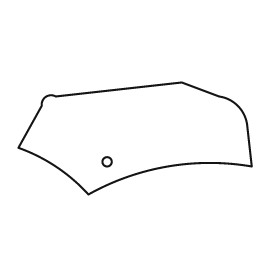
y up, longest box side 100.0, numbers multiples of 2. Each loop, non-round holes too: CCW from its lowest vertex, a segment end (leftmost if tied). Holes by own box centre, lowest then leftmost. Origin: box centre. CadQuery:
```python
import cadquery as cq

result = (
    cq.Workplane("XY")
    .moveTo(-20.0, -24.0)
    .threePointArc((14.0, -12.0), (50.0, -12.0))
    .lineTo(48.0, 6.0)
    .threePointArc((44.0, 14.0), (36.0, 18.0))
    .lineTo(20.0, 24.0)
    .lineTo(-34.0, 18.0)
    .threePointArc((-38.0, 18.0), (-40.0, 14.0))
    .lineTo(-50.0, -4.0)
    .threePointArc((-34.0, -12.0), (-20.0, -24.0))
    .close()
    .moveTo(-12.0, -10.0)
    .circle(2.0)
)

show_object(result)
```